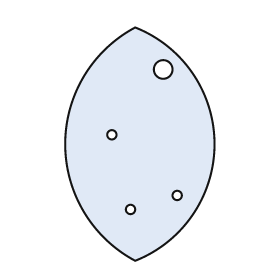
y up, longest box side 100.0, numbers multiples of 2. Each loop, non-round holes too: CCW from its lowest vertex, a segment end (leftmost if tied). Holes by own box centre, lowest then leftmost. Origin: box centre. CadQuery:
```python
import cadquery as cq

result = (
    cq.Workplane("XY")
    .moveTo(-2.0, -50.0)
    .threePointArc((32.0, 0.0), (-2.0, 50.0))
    .threePointArc((-32.0, 0.0), (-2.0, -50.0))
    .close()
    .moveTo(-4.0, -28.0)
    .circle(2.0)
    .moveTo(16.0, -22.0)
    .circle(2.0)
    .moveTo(-12.0, 4.0)
    .circle(2.0)
    .moveTo(10.0, 32.0)
    .circle(4.0)
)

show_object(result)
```